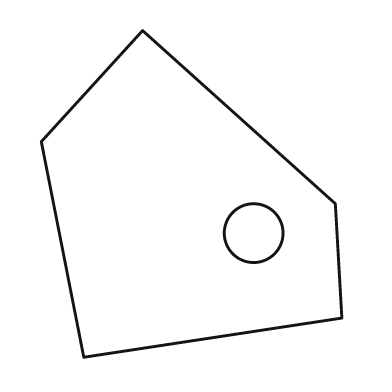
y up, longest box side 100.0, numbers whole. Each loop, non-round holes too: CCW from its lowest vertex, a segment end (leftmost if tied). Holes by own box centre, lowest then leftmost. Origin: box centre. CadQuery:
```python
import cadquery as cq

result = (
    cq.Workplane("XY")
    .moveTo(-33.0, -50.0)
    .lineTo(46.0, -38.0)
    .lineTo(44.0, -3.0)
    .lineTo(-15.0, 50.0)
    .lineTo(-46.0, 16.0)
    .close()
    .moveTo(19.0, -12.0)
    .circle(9.0)
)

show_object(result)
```